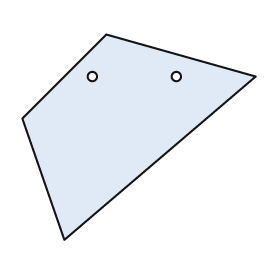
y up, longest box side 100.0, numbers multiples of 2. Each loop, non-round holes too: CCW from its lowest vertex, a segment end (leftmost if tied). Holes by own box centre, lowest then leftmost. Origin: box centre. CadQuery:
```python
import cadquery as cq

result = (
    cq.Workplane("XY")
    .moveTo(-32.0, -44.0)
    .lineTo(50.0, 26.0)
    .lineTo(-14.0, 44.0)
    .lineTo(-50.0, 8.0)
    .close()
    .moveTo(-20.0, 26.0)
    .circle(2.0)
    .moveTo(16.0, 26.0)
    .circle(2.0)
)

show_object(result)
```